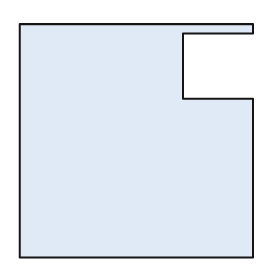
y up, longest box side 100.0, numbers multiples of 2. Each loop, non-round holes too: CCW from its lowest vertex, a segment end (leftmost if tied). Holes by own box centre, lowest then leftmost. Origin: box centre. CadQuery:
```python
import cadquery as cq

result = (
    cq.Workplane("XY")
    .moveTo(-50.0, -50.0)
    .lineTo(50.0, -50.0)
    .lineTo(50.0, 18.0)
    .lineTo(20.0, 18.0)
    .lineTo(20.0, 46.0)
    .lineTo(50.0, 46.0)
    .lineTo(50.0, 50.0)
    .lineTo(-50.0, 50.0)
    .close()
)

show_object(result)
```